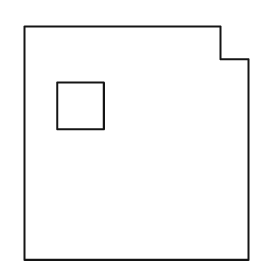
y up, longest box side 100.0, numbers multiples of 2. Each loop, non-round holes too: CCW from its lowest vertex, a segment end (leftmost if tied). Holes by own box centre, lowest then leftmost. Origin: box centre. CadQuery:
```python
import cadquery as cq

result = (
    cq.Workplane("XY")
    .moveTo(-48.0, -50.0)
    .lineTo(48.0, -50.0)
    .lineTo(48.0, 36.0)
    .lineTo(36.0, 36.0)
    .lineTo(36.0, 50.0)
    .lineTo(-48.0, 50.0)
    .close()
    .moveTo(-34.0, 6.0)
    .lineTo(-14.0, 6.0)
    .lineTo(-14.0, 26.0)
    .lineTo(-34.0, 26.0)
    .close()
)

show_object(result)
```